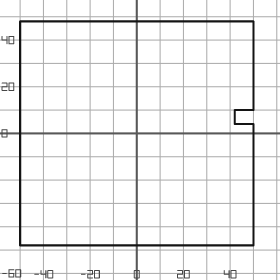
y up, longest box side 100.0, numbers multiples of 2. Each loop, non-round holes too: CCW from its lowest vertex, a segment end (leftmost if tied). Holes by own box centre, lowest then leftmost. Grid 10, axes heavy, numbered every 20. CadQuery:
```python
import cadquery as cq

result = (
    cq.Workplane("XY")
    .moveTo(-50.0, -48.0)
    .lineTo(50.0, -48.0)
    .lineTo(50.0, 4.0)
    .lineTo(42.0, 4.0)
    .lineTo(42.0, 10.0)
    .lineTo(50.0, 10.0)
    .lineTo(50.0, 48.0)
    .lineTo(-50.0, 48.0)
    .close()
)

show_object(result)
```